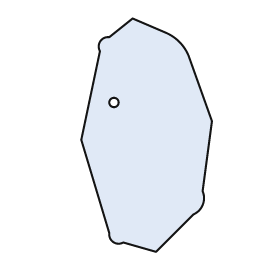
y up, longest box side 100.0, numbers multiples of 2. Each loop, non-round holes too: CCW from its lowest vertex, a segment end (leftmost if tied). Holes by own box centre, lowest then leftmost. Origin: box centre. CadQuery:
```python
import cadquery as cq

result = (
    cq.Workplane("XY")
    .moveTo(4.0, -50.0)
    .lineTo(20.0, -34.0)
    .threePointArc((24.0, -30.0), (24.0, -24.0))
    .lineTo(28.0, 6.0)
    .lineTo(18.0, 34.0)
    .threePointArc((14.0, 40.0), (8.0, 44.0))
    .lineTo(-6.0, 50.0)
    .lineTo(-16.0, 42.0)
    .threePointArc((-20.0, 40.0), (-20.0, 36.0))
    .lineTo(-28.0, -2.0)
    .lineTo(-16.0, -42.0)
    .threePointArc((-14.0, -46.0), (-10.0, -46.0))
    .close()
    .moveTo(-14.0, 14.0)
    .circle(2.0)
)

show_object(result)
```